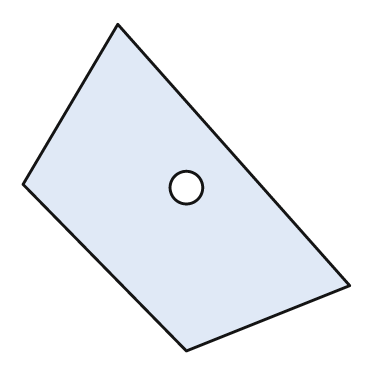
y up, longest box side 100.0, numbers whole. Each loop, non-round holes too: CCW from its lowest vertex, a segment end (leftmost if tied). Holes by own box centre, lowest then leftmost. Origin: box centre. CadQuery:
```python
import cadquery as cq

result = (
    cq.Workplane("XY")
    .moveTo(0.0, -50.0)
    .lineTo(50.0, -30.0)
    .lineTo(-21.0, 50.0)
    .lineTo(-50.0, 1.0)
    .close()
    .moveTo(0.0, 0.0)
    .circle(5.0)
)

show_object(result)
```